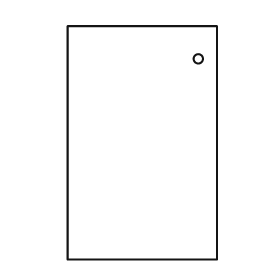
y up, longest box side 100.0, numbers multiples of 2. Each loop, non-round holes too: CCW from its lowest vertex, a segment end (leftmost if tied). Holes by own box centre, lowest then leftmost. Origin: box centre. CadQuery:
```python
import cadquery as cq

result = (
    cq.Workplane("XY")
    .moveTo(-32.0, -50.0)
    .lineTo(32.0, -50.0)
    .lineTo(32.0, 50.0)
    .lineTo(-32.0, 50.0)
    .close()
    .moveTo(24.0, 36.0)
    .circle(2.0)
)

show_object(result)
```